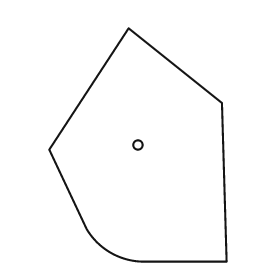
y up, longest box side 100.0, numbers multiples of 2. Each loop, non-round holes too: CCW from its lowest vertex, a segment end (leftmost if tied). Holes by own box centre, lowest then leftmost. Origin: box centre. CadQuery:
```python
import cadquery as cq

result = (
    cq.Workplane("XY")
    .moveTo(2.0, -50.0)
    .lineTo(38.0, -50.0)
    .lineTo(36.0, 18.0)
    .lineTo(-4.0, 50.0)
    .lineTo(-38.0, -2.0)
    .lineTo(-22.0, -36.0)
    .threePointArc((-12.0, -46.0), (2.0, -50.0))
    .close()
    .moveTo(0.0, 0.0)
    .circle(2.0)
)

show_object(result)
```